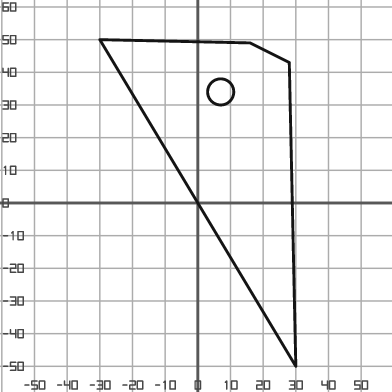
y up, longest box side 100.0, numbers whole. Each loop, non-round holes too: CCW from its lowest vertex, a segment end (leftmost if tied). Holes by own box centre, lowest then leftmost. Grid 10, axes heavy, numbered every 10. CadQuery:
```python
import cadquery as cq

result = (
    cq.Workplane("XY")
    .moveTo(30.0, -50.0)
    .lineTo(28.0, 43.0)
    .lineTo(16.0, 49.0)
    .lineTo(-30.0, 50.0)
    .close()
    .moveTo(7.0, 34.0)
    .circle(4.0)
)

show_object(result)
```